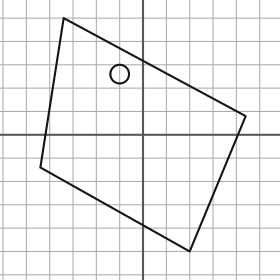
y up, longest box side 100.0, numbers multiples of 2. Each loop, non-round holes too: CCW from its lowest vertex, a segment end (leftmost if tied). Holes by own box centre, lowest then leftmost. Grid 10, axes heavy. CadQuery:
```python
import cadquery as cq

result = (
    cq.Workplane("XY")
    .moveTo(20.0, -50.0)
    .lineTo(44.0, 8.0)
    .lineTo(-34.0, 50.0)
    .lineTo(-44.0, -14.0)
    .close()
    .moveTo(-10.0, 26.0)
    .circle(4.0)
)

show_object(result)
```